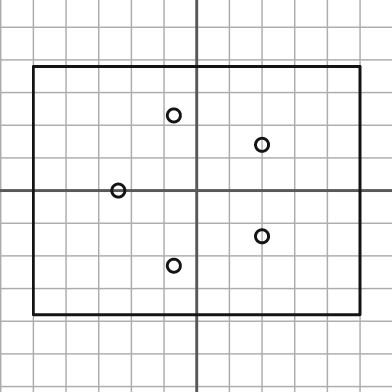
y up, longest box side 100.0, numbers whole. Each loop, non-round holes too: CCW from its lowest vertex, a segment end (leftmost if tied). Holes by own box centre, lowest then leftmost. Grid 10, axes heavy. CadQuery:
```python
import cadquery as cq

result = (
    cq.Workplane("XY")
    .moveTo(-50.0, -38.0)
    .lineTo(50.0, -38.0)
    .lineTo(50.0, 38.0)
    .lineTo(-50.0, 38.0)
    .close()
    .moveTo(-7.0, -23.0)
    .circle(2.0)
    .moveTo(20.0, -14.0)
    .circle(2.0)
    .moveTo(-24.0, 0.0)
    .circle(2.0)
    .moveTo(20.0, 14.0)
    .circle(2.0)
    .moveTo(-7.0, 23.0)
    .circle(2.0)
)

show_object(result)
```